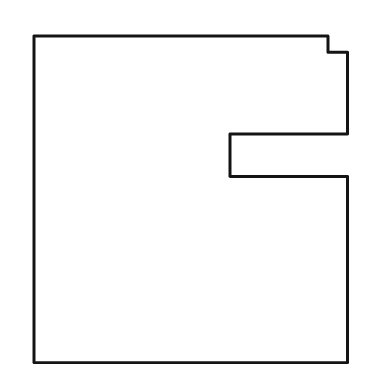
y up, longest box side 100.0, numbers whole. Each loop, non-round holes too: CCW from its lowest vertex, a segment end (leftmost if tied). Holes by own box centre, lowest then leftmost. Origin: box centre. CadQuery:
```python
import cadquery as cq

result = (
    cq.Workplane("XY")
    .moveTo(-48.0, -50.0)
    .lineTo(48.0, -50.0)
    .lineTo(48.0, 7.0)
    .lineTo(12.0, 7.0)
    .lineTo(12.0, 20.0)
    .lineTo(48.0, 20.0)
    .lineTo(48.0, 45.0)
    .lineTo(42.0, 45.0)
    .lineTo(42.0, 50.0)
    .lineTo(-48.0, 50.0)
    .close()
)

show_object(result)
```